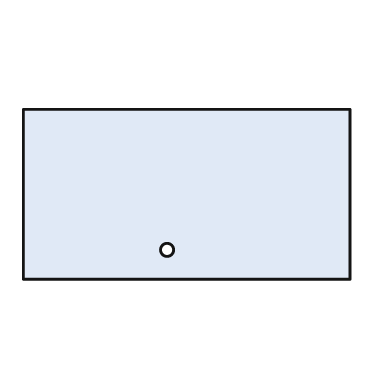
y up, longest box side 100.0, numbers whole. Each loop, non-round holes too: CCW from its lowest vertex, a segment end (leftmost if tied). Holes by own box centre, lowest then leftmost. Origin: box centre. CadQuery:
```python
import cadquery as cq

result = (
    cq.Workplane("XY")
    .moveTo(-50.0, -26.0)
    .lineTo(50.0, -26.0)
    .lineTo(50.0, 26.0)
    .lineTo(-50.0, 26.0)
    .close()
    .moveTo(-6.0, -17.0)
    .circle(2.0)
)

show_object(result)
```